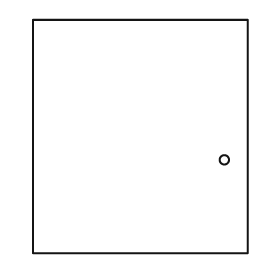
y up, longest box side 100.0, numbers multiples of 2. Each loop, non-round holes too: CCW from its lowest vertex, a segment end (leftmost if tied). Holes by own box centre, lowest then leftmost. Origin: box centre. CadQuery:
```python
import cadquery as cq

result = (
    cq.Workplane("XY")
    .moveTo(-46.0, -50.0)
    .lineTo(46.0, -50.0)
    .lineTo(46.0, 50.0)
    .lineTo(-46.0, 50.0)
    .close()
    .moveTo(36.0, -10.0)
    .circle(2.0)
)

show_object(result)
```